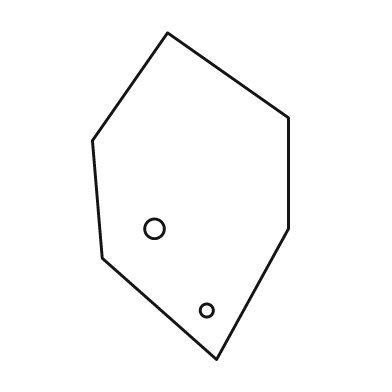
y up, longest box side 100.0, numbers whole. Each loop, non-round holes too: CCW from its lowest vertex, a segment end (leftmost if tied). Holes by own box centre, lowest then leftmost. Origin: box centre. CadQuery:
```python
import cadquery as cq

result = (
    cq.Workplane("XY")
    .moveTo(8.0, -50.0)
    .lineTo(30.0, -10.0)
    .lineTo(30.0, 24.0)
    .lineTo(-7.0, 50.0)
    .lineTo(-30.0, 17.0)
    .lineTo(-27.0, -19.0)
    .close()
    .moveTo(5.0, -35.0)
    .circle(2.0)
    .moveTo(-11.0, -10.0)
    .circle(3.0)
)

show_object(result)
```